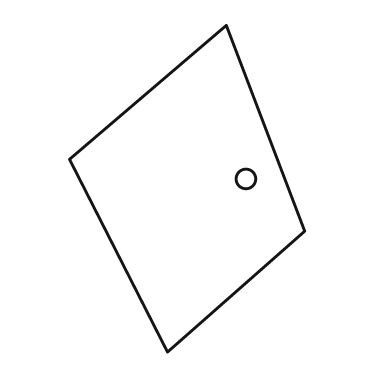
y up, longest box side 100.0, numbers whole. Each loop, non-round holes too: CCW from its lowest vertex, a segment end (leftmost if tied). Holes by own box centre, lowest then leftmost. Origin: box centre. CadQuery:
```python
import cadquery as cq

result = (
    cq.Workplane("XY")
    .moveTo(-6.0, -50.0)
    .lineTo(36.0, -13.0)
    .lineTo(12.0, 50.0)
    .lineTo(-36.0, 9.0)
    .close()
    .moveTo(18.0, 3.0)
    .circle(3.0)
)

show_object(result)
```